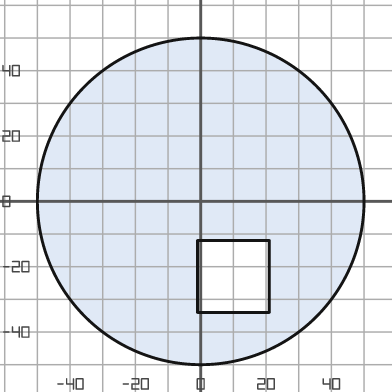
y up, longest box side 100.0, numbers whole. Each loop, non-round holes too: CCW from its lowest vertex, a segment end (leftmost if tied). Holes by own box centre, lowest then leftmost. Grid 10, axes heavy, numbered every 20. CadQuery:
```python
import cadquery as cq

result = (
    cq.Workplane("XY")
    .moveTo(0.0, 0.0)
    .circle(50.0)
    .moveTo(-1.0, -34.0)
    .lineTo(21.0, -34.0)
    .lineTo(21.0, -12.0)
    .lineTo(-1.0, -12.0)
    .close()
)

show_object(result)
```